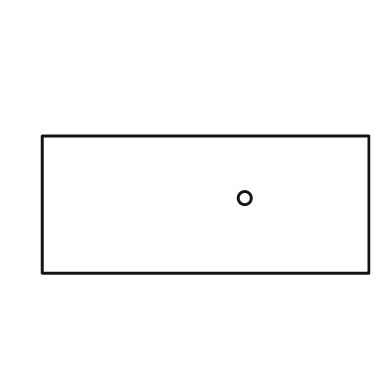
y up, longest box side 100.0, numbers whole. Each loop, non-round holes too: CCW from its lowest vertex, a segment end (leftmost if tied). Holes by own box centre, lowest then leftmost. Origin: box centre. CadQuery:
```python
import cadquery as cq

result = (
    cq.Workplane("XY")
    .moveTo(-50.0, -21.0)
    .lineTo(50.0, -21.0)
    .lineTo(50.0, 21.0)
    .lineTo(-50.0, 21.0)
    .close()
    .moveTo(12.0, 2.0)
    .circle(2.0)
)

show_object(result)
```